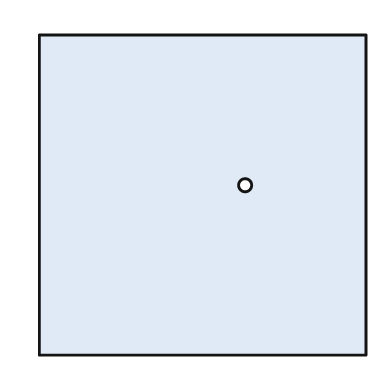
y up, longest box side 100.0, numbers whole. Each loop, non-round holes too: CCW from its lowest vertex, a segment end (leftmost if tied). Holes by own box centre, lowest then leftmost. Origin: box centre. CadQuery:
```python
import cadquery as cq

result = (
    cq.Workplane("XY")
    .moveTo(-50.0, -49.0)
    .lineTo(50.0, -49.0)
    .lineTo(50.0, 49.0)
    .lineTo(-50.0, 49.0)
    .close()
    .moveTo(13.0, 3.0)
    .circle(2.0)
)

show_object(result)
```